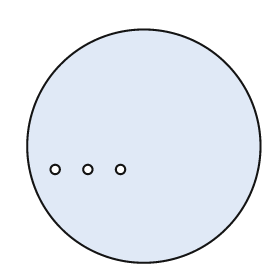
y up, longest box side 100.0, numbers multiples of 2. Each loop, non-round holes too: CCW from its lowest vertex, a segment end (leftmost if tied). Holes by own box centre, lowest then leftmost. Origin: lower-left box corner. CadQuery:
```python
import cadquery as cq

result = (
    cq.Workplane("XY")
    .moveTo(50.0, 50.0)
    .circle(50.0)
    .moveTo(12.0, 40.0)
    .circle(2.0)
    .moveTo(26.0, 40.0)
    .circle(2.0)
    .moveTo(40.0, 40.0)
    .circle(2.0)
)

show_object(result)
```